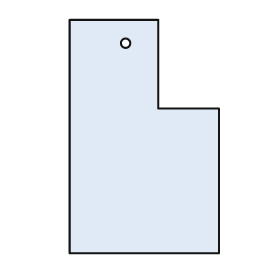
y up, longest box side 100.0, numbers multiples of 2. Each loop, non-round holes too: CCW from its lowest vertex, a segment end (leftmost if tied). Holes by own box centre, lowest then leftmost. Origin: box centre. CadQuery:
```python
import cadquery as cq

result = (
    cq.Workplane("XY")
    .moveTo(-32.0, -50.0)
    .lineTo(32.0, -50.0)
    .lineTo(32.0, 12.0)
    .lineTo(6.0, 12.0)
    .lineTo(6.0, 50.0)
    .lineTo(-32.0, 50.0)
    .close()
    .moveTo(-8.0, 40.0)
    .circle(2.0)
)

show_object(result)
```